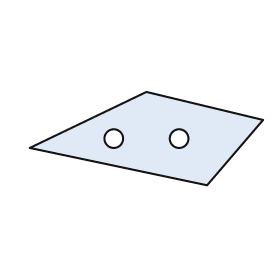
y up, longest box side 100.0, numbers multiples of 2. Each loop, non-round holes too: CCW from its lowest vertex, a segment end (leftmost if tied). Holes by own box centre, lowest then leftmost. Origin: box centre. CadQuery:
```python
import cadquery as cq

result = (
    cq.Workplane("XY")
    .moveTo(26.0, -20.0)
    .lineTo(50.0, 8.0)
    .lineTo(0.0, 20.0)
    .lineTo(-50.0, -4.0)
    .close()
    .moveTo(-14.0, 0.0)
    .circle(4.0)
    .moveTo(14.0, 0.0)
    .circle(4.0)
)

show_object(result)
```